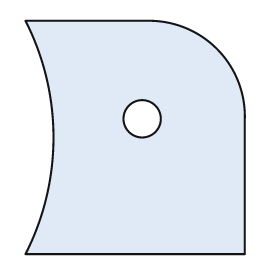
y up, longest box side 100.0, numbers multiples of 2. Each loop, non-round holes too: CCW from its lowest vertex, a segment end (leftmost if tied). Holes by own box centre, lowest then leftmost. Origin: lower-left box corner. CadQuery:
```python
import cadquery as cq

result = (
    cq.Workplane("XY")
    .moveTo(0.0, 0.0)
    .lineTo(94.0, 0.0)
    .lineTo(94.0, 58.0)
    .threePointArc((82.0, 88.0), (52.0, 100.0))
    .lineTo(0.0, 100.0)
    .threePointArc((12.0, 50.0), (0.0, 0.0))
    .close()
    .moveTo(50.0, 58.0)
    .circle(8.0)
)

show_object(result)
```